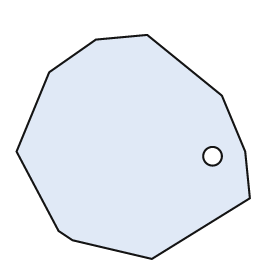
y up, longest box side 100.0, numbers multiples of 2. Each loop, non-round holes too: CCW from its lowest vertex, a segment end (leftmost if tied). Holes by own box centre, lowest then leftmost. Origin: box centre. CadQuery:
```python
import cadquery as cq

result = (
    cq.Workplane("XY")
    .moveTo(8.0, -48.0)
    .lineTo(50.0, -22.0)
    .lineTo(48.0, -2.0)
    .lineTo(38.0, 22.0)
    .lineTo(6.0, 48.0)
    .lineTo(-16.0, 46.0)
    .lineTo(-36.0, 32.0)
    .lineTo(-50.0, -2.0)
    .lineTo(-32.0, -36.0)
    .lineTo(-26.0, -40.0)
    .close()
    .moveTo(34.0, -4.0)
    .circle(4.0)
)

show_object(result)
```